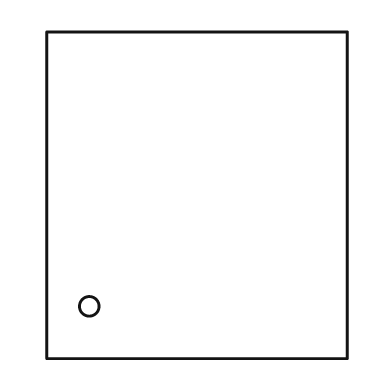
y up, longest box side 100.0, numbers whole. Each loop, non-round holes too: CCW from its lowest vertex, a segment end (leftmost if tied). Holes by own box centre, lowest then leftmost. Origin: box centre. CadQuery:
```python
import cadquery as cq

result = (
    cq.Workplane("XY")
    .moveTo(-46.0, -50.0)
    .lineTo(46.0, -50.0)
    .lineTo(46.0, 50.0)
    .lineTo(-46.0, 50.0)
    .close()
    .moveTo(-33.0, -34.0)
    .circle(3.0)
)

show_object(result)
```